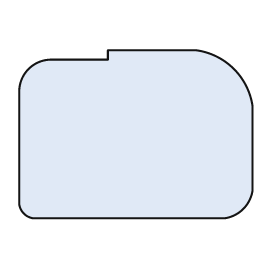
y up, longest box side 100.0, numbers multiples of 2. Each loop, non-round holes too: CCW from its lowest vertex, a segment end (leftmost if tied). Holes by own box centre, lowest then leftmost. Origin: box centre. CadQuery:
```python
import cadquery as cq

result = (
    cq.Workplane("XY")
    .moveTo(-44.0, -36.0)
    .lineTo(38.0, -36.0)
    .threePointArc((46.0, -32.0), (50.0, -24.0))
    .lineTo(50.0, 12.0)
    .threePointArc((42.0, 28.0), (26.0, 36.0))
    .lineTo(-12.0, 36.0)
    .lineTo(-12.0, 32.0)
    .lineTo(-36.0, 32.0)
    .threePointArc((-46.0, 28.0), (-50.0, 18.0))
    .lineTo(-50.0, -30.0)
    .threePointArc((-48.0, -34.0), (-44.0, -36.0))
    .close()
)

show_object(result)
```